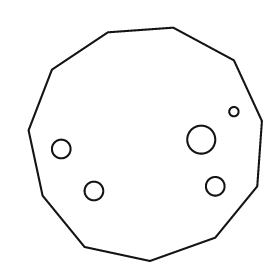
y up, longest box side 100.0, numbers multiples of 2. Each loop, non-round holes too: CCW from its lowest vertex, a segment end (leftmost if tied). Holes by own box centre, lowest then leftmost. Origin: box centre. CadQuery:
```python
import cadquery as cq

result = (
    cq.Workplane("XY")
    .moveTo(2.0, -50.0)
    .lineTo(30.0, -40.0)
    .lineTo(48.0, -18.0)
    .lineTo(50.0, 10.0)
    .lineTo(38.0, 36.0)
    .lineTo(12.0, 50.0)
    .lineTo(-16.0, 48.0)
    .lineTo(-40.0, 32.0)
    .lineTo(-50.0, 6.0)
    .lineTo(-44.0, -22.0)
    .lineTo(-26.0, -44.0)
    .close()
    .moveTo(-22.0, -20.0)
    .circle(4.0)
    .moveTo(30.0, -18.0)
    .circle(4.0)
    .moveTo(-36.0, -2.0)
    .circle(4.0)
    .moveTo(24.0, 2.0)
    .circle(6.0)
    .moveTo(38.0, 14.0)
    .circle(2.0)
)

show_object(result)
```